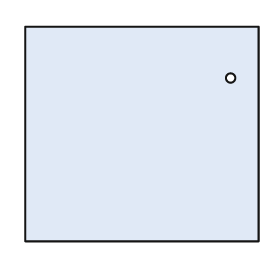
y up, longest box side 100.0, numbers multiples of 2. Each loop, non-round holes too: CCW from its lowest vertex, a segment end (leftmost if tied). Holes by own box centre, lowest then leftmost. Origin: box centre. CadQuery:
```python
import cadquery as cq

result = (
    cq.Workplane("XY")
    .moveTo(-50.0, -46.0)
    .lineTo(50.0, -46.0)
    .lineTo(50.0, 46.0)
    .lineTo(-50.0, 46.0)
    .close()
    .moveTo(38.0, 24.0)
    .circle(2.0)
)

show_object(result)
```